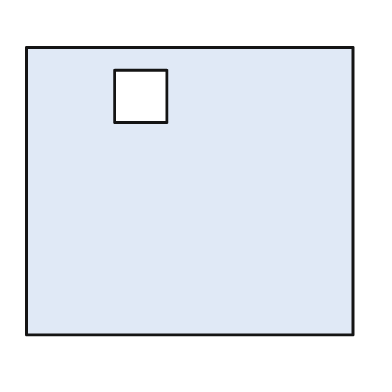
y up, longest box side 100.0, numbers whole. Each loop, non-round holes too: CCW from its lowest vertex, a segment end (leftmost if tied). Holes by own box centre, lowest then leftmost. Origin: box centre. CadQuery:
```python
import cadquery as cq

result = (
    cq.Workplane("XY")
    .moveTo(-50.0, -44.0)
    .lineTo(50.0, -44.0)
    .lineTo(50.0, 44.0)
    .lineTo(-50.0, 44.0)
    .close()
    .moveTo(-23.0, 21.0)
    .lineTo(-7.0, 21.0)
    .lineTo(-7.0, 37.0)
    .lineTo(-23.0, 37.0)
    .close()
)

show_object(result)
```